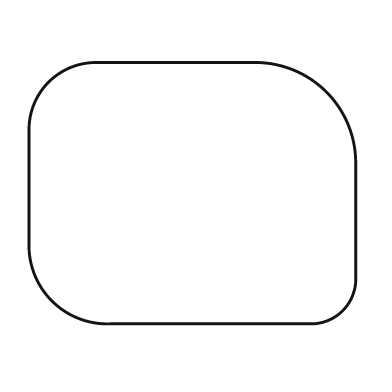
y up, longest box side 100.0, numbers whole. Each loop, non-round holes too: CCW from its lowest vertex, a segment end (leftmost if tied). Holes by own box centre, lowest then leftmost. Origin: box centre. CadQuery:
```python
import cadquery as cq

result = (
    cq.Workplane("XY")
    .moveTo(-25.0, -40.0)
    .lineTo(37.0, -40.0)
    .threePointArc((46.0, -36.0), (50.0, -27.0))
    .lineTo(50.0, 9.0)
    .threePointArc((41.0, 31.0), (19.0, 40.0))
    .lineTo(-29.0, 40.0)
    .threePointArc((-44.0, 34.0), (-50.0, 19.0))
    .lineTo(-50.0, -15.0)
    .threePointArc((-43.0, -33.0), (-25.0, -40.0))
    .close()
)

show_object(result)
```